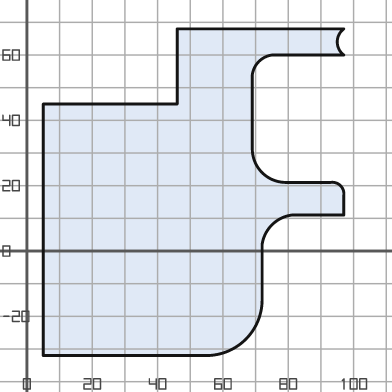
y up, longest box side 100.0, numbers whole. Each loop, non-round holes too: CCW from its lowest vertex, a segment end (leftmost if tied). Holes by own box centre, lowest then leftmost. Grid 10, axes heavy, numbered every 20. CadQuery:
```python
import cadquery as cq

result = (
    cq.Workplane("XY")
    .moveTo(5.0, -32.0)
    .lineTo(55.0, -32.0)
    .threePointArc((67.0, -27.0), (72.0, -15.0))
    .lineTo(72.0, 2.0)
    .threePointArc((75.0, 8.0), (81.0, 11.0))
    .lineTo(97.0, 11.0)
    .lineTo(97.0, 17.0)
    .threePointArc((96.0, 20.0), (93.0, 21.0))
    .lineTo(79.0, 21.0)
    .threePointArc((72.0, 24.0), (69.0, 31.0))
    .lineTo(69.0, 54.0)
    .threePointArc((71.0, 58.0), (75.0, 60.0))
    .lineTo(97.0, 60.0)
    .threePointArc((95.0, 64.0), (97.0, 68.0))
    .lineTo(46.0, 68.0)
    .lineTo(46.0, 45.0)
    .lineTo(5.0, 45.0)
    .close()
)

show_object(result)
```